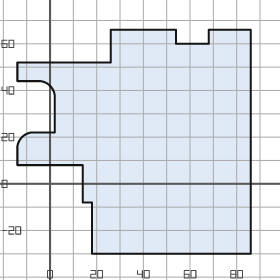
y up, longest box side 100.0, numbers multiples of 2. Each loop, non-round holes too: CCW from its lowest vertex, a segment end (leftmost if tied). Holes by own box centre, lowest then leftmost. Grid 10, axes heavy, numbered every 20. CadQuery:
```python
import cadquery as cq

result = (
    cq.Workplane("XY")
    .moveTo(18.0, -30.0)
    .lineTo(86.0, -30.0)
    .lineTo(86.0, 66.0)
    .lineTo(68.0, 66.0)
    .lineTo(68.0, 60.0)
    .lineTo(54.0, 60.0)
    .lineTo(54.0, 66.0)
    .lineTo(26.0, 66.0)
    .lineTo(26.0, 52.0)
    .lineTo(-14.0, 52.0)
    .lineTo(-14.0, 44.0)
    .lineTo(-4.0, 44.0)
    .threePointArc((0.0, 42.0), (2.0, 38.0))
    .lineTo(2.0, 22.0)
    .lineTo(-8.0, 22.0)
    .threePointArc((-12.0, 20.0), (-14.0, 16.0))
    .lineTo(-14.0, 8.0)
    .lineTo(14.0, 8.0)
    .lineTo(14.0, -8.0)
    .lineTo(18.0, -8.0)
    .close()
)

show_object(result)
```